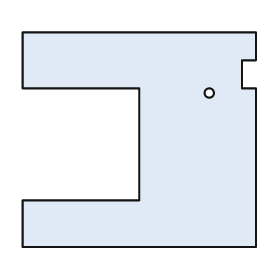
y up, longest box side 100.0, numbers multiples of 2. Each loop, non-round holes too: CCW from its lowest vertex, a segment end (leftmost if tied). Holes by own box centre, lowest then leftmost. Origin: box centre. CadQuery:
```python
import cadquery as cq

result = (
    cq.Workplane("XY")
    .moveTo(-50.0, -46.0)
    .lineTo(50.0, -46.0)
    .lineTo(50.0, 22.0)
    .lineTo(44.0, 22.0)
    .lineTo(44.0, 34.0)
    .lineTo(50.0, 34.0)
    .lineTo(50.0, 46.0)
    .lineTo(-50.0, 46.0)
    .lineTo(-50.0, 22.0)
    .lineTo(0.0, 22.0)
    .lineTo(0.0, -26.0)
    .lineTo(-50.0, -26.0)
    .close()
    .moveTo(30.0, 20.0)
    .circle(2.0)
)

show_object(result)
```